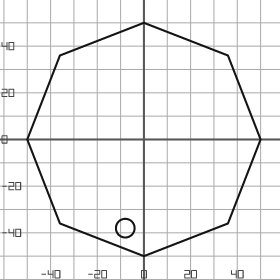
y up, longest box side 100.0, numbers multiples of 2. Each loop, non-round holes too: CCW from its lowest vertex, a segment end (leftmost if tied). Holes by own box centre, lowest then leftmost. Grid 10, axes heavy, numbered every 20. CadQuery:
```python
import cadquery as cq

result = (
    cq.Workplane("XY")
    .moveTo(0.0, -50.0)
    .lineTo(36.0, -36.0)
    .lineTo(50.0, 0.0)
    .lineTo(36.0, 36.0)
    .lineTo(0.0, 50.0)
    .lineTo(-36.0, 36.0)
    .lineTo(-50.0, 0.0)
    .lineTo(-36.0, -36.0)
    .close()
    .moveTo(-8.0, -38.0)
    .circle(4.0)
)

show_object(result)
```